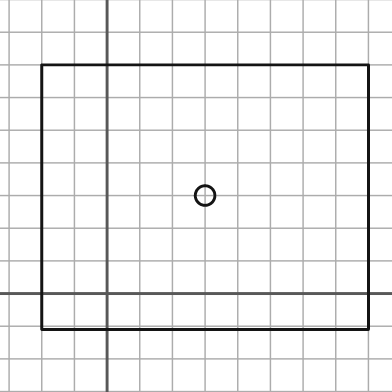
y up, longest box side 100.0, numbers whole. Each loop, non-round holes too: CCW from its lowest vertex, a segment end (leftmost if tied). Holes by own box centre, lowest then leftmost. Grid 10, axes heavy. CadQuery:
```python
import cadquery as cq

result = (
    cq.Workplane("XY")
    .moveTo(-20.0, -11.0)
    .lineTo(80.0, -11.0)
    .lineTo(80.0, 70.0)
    .lineTo(-20.0, 70.0)
    .close()
    .moveTo(30.0, 30.0)
    .circle(3.0)
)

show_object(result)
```